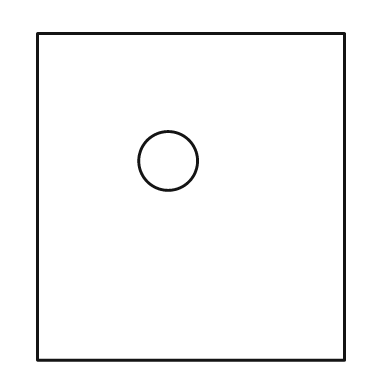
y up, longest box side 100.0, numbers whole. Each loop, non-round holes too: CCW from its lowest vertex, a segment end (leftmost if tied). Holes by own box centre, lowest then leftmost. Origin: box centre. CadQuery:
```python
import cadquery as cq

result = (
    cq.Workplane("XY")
    .moveTo(-47.0, -50.0)
    .lineTo(47.0, -50.0)
    .lineTo(47.0, 50.0)
    .lineTo(-47.0, 50.0)
    .close()
    .moveTo(-7.0, 11.0)
    .circle(9.0)
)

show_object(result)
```